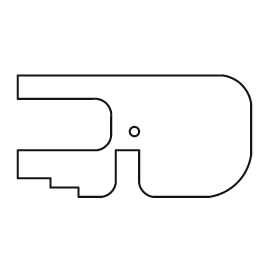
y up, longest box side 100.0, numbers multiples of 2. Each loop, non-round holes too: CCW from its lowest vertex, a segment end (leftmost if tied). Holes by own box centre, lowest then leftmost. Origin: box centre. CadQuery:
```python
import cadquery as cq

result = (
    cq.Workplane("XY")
    .moveTo(-24.0, -26.0)
    .lineTo(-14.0, -26.0)
    .threePointArc((-10.0, -24.0), (-8.0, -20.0))
    .lineTo(-8.0, -6.0)
    .lineTo(2.0, -6.0)
    .lineTo(2.0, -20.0)
    .threePointArc((4.0, -24.0), (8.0, -26.0))
    .lineTo(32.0, -26.0)
    .threePointArc((44.0, -20.0), (50.0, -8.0))
    .lineTo(50.0, 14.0)
    .threePointArc((46.0, 22.0), (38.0, 26.0))
    .lineTo(-50.0, 26.0)
    .lineTo(-50.0, 16.0)
    .lineTo(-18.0, 16.0)
    .threePointArc((-12.0, 14.0), (-10.0, 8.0))
    .lineTo(-10.0, 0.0)
    .threePointArc((-12.0, -4.0), (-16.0, -6.0))
    .lineTo(-50.0, -6.0)
    .lineTo(-50.0, -18.0)
    .lineTo(-36.0, -18.0)
    .lineTo(-36.0, -22.0)
    .lineTo(-24.0, -22.0)
    .close()
    .moveTo(0.0, 2.0)
    .circle(2.0)
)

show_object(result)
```